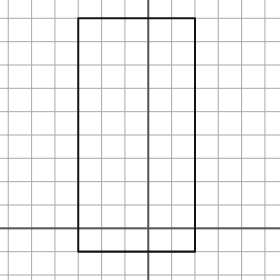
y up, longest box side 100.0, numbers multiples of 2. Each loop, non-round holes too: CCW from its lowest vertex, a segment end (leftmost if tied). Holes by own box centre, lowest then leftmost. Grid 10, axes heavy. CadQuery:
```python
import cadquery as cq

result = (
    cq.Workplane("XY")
    .moveTo(-30.0, -10.0)
    .lineTo(20.0, -10.0)
    .lineTo(20.0, 90.0)
    .lineTo(-30.0, 90.0)
    .close()
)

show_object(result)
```